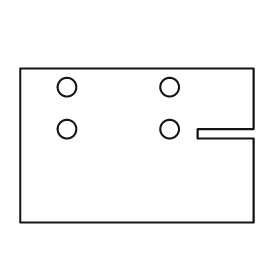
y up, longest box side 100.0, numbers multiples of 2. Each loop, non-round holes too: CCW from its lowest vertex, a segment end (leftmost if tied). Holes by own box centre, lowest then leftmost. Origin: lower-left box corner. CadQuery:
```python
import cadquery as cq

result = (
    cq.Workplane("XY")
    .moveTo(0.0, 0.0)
    .lineTo(100.0, 0.0)
    .lineTo(100.0, 36.0)
    .lineTo(76.0, 36.0)
    .lineTo(76.0, 40.0)
    .lineTo(100.0, 40.0)
    .lineTo(100.0, 66.0)
    .lineTo(0.0, 66.0)
    .close()
    .moveTo(20.0, 40.0)
    .circle(4.0)
    .moveTo(64.0, 40.0)
    .circle(4.0)
    .moveTo(20.0, 58.0)
    .circle(4.0)
    .moveTo(64.0, 58.0)
    .circle(4.0)
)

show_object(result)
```